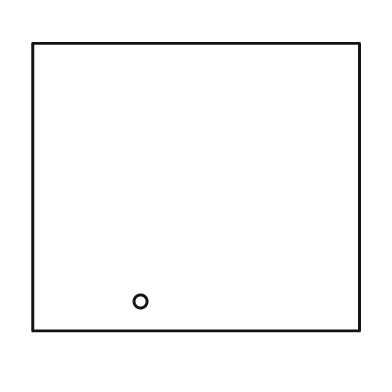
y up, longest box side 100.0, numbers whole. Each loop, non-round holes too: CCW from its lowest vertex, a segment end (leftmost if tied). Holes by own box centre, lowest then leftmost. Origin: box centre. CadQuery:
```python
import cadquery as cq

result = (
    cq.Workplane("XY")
    .moveTo(-50.0, -44.0)
    .lineTo(50.0, -44.0)
    .lineTo(50.0, 44.0)
    .lineTo(-50.0, 44.0)
    .close()
    .moveTo(-17.0, -35.0)
    .circle(2.0)
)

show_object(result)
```